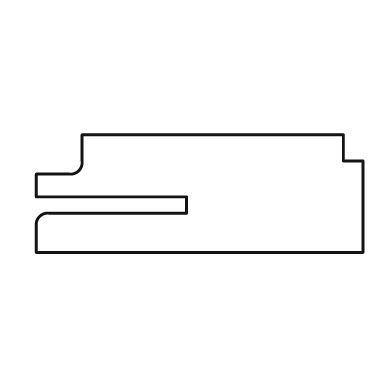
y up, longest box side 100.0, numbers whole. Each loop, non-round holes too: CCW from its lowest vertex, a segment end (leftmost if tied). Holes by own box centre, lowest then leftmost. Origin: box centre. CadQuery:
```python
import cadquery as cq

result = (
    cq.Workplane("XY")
    .moveTo(-50.0, -18.0)
    .lineTo(50.0, -18.0)
    .lineTo(50.0, 10.0)
    .lineTo(44.0, 10.0)
    .lineTo(44.0, 18.0)
    .lineTo(-36.0, 18.0)
    .lineTo(-36.0, 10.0)
    .threePointArc((-37.0, 7.0), (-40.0, 6.0))
    .lineTo(-50.0, 6.0)
    .lineTo(-50.0, -1.0)
    .lineTo(-4.0, -1.0)
    .lineTo(-4.0, -6.0)
    .lineTo(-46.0, -6.0)
    .threePointArc((-49.0, -7.0), (-50.0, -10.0))
    .close()
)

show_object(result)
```